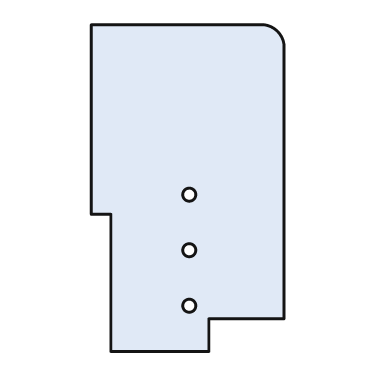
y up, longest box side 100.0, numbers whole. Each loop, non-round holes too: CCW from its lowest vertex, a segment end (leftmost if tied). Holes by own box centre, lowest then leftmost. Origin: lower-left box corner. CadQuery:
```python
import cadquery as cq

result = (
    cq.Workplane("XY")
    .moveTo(6.0, 0.0)
    .lineTo(36.0, 0.0)
    .lineTo(36.0, 10.0)
    .lineTo(59.0, 10.0)
    .lineTo(59.0, 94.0)
    .threePointArc((57.0, 98.0), (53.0, 100.0))
    .lineTo(0.0, 100.0)
    .lineTo(0.0, 42.0)
    .lineTo(6.0, 42.0)
    .close()
    .moveTo(30.0, 14.0)
    .circle(2.0)
    .moveTo(30.0, 31.0)
    .circle(2.0)
    .moveTo(30.0, 48.0)
    .circle(2.0)
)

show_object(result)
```